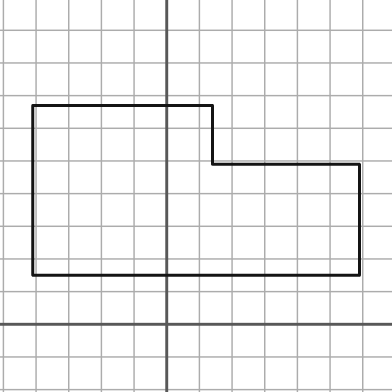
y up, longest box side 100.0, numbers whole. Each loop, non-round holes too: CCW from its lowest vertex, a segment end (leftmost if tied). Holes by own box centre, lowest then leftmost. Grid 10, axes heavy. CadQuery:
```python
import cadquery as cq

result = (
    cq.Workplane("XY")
    .moveTo(-41.0, 15.0)
    .lineTo(59.0, 15.0)
    .lineTo(59.0, 49.0)
    .lineTo(14.0, 49.0)
    .lineTo(14.0, 67.0)
    .lineTo(-41.0, 67.0)
    .close()
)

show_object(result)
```